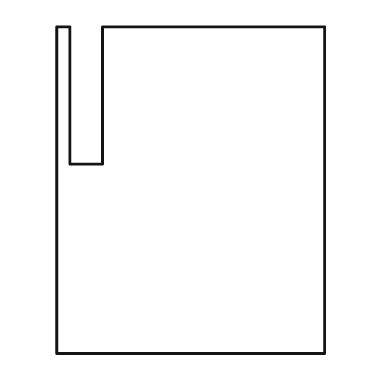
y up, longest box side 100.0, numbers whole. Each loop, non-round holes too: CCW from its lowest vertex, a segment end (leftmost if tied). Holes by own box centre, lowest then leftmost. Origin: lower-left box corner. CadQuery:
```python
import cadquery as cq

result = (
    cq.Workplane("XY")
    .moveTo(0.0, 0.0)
    .lineTo(82.0, 0.0)
    .lineTo(82.0, 100.0)
    .lineTo(14.0, 100.0)
    .lineTo(14.0, 58.0)
    .lineTo(4.0, 58.0)
    .lineTo(4.0, 100.0)
    .lineTo(0.0, 100.0)
    .close()
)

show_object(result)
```